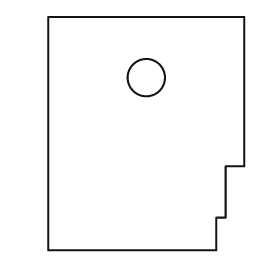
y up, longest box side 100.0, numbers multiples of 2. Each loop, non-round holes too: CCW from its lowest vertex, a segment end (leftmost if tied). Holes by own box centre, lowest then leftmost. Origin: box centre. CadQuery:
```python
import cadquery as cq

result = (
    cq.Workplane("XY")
    .moveTo(-42.0, -50.0)
    .lineTo(30.0, -50.0)
    .lineTo(30.0, -36.0)
    .lineTo(34.0, -36.0)
    .lineTo(34.0, -14.0)
    .lineTo(42.0, -14.0)
    .lineTo(42.0, 50.0)
    .lineTo(-42.0, 50.0)
    .close()
    .moveTo(0.0, 24.0)
    .circle(8.0)
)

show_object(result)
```